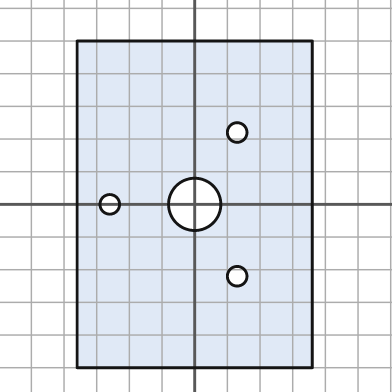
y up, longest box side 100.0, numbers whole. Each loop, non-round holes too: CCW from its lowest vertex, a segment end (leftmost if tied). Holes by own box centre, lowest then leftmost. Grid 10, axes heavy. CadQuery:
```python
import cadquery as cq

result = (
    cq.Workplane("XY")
    .moveTo(-36.0, -50.0)
    .lineTo(36.0, -50.0)
    .lineTo(36.0, 50.0)
    .lineTo(-36.0, 50.0)
    .close()
    .moveTo(13.0, -22.0)
    .circle(3.0)
    .moveTo(-26.0, 0.0)
    .circle(3.0)
    .moveTo(0.0, 0.0)
    .circle(8.0)
    .moveTo(13.0, 22.0)
    .circle(3.0)
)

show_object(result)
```